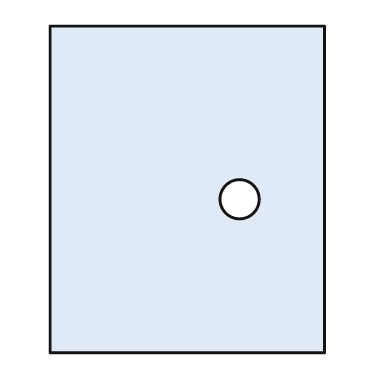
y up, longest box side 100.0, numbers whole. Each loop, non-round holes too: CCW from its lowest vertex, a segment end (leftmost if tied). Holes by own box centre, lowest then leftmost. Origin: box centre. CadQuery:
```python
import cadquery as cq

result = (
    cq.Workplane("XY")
    .moveTo(-42.0, -50.0)
    .lineTo(42.0, -50.0)
    .lineTo(42.0, 50.0)
    .lineTo(-42.0, 50.0)
    .close()
    .moveTo(16.0, -3.0)
    .circle(6.0)
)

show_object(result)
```